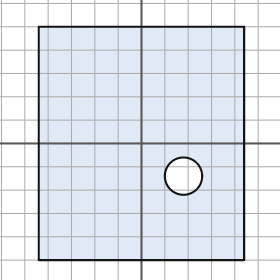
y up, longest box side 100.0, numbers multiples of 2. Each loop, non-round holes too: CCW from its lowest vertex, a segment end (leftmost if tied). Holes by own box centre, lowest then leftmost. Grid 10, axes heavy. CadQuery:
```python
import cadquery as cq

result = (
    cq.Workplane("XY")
    .moveTo(-44.0, -50.0)
    .lineTo(44.0, -50.0)
    .lineTo(44.0, 50.0)
    .lineTo(-44.0, 50.0)
    .close()
    .moveTo(18.0, -14.0)
    .circle(8.0)
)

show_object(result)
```